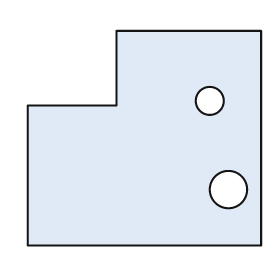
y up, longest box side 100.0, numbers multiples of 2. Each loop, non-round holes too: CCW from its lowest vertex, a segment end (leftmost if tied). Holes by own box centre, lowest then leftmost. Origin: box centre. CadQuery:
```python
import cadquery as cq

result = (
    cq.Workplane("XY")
    .moveTo(-50.0, -46.0)
    .lineTo(50.0, -46.0)
    .lineTo(50.0, 46.0)
    .lineTo(-12.0, 46.0)
    .lineTo(-12.0, 14.0)
    .lineTo(-50.0, 14.0)
    .close()
    .moveTo(36.0, -22.0)
    .circle(8.0)
    .moveTo(28.0, 16.0)
    .circle(6.0)
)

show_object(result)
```